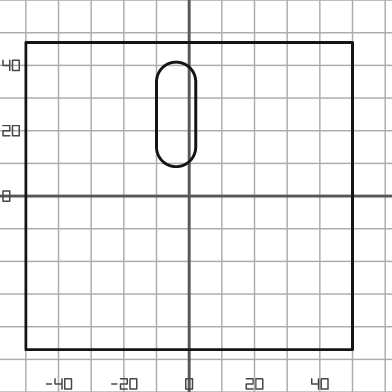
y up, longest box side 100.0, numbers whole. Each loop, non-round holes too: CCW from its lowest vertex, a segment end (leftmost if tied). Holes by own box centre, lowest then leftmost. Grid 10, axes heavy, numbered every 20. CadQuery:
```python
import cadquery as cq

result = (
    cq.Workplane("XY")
    .moveTo(-50.0, -47.0)
    .lineTo(50.0, -47.0)
    .lineTo(50.0, 47.0)
    .lineTo(-50.0, 47.0)
    .close()
    .moveTo(-10.0, 15.0)
    .threePointArc((-4.0, 9.0), (2.0, 15.0))
    .lineTo(2.0, 35.0)
    .threePointArc((-4.0, 41.0), (-10.0, 35.0))
    .close()
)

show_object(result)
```